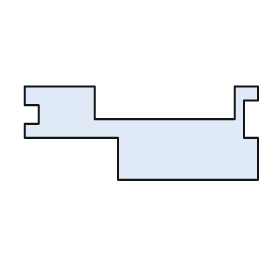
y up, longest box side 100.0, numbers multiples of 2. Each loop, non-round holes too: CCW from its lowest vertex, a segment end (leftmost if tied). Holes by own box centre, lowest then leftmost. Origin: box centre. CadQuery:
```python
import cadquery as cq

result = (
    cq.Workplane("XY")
    .moveTo(-10.0, -20.0)
    .lineTo(50.0, -20.0)
    .lineTo(50.0, -2.0)
    .lineTo(44.0, -2.0)
    .lineTo(44.0, 14.0)
    .lineTo(50.0, 14.0)
    .lineTo(50.0, 20.0)
    .lineTo(40.0, 20.0)
    .lineTo(40.0, 6.0)
    .lineTo(-20.0, 6.0)
    .lineTo(-20.0, 20.0)
    .lineTo(-50.0, 20.0)
    .lineTo(-50.0, 12.0)
    .lineTo(-44.0, 12.0)
    .lineTo(-44.0, 4.0)
    .lineTo(-50.0, 4.0)
    .lineTo(-50.0, -2.0)
    .lineTo(-10.0, -2.0)
    .close()
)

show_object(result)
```